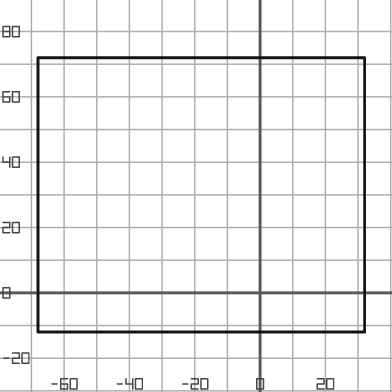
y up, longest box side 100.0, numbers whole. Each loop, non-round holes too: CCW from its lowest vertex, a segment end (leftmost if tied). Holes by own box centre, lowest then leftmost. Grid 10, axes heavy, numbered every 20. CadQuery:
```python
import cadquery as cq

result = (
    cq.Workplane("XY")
    .moveTo(-68.0, -12.0)
    .lineTo(32.0, -12.0)
    .lineTo(32.0, 72.0)
    .lineTo(-68.0, 72.0)
    .close()
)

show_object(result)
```